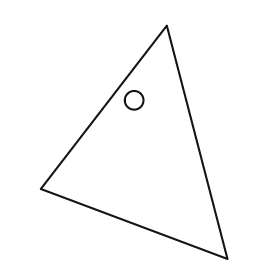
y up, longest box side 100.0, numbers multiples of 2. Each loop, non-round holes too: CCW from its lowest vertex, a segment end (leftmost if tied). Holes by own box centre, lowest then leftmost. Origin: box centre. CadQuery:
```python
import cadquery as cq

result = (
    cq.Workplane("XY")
    .moveTo(40.0, -50.0)
    .lineTo(14.0, 50.0)
    .lineTo(-40.0, -20.0)
    .close()
    .moveTo(0.0, 18.0)
    .circle(4.0)
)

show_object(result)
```